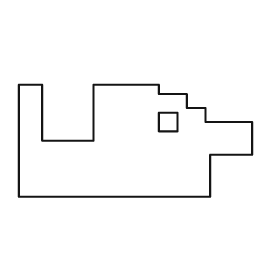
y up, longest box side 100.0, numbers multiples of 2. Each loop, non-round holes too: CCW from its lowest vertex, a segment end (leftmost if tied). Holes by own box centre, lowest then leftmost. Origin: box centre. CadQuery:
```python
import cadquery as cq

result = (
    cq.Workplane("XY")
    .moveTo(-50.0, -24.0)
    .lineTo(32.0, -24.0)
    .lineTo(32.0, -6.0)
    .lineTo(50.0, -6.0)
    .lineTo(50.0, 8.0)
    .lineTo(30.0, 8.0)
    .lineTo(30.0, 14.0)
    .lineTo(22.0, 14.0)
    .lineTo(22.0, 20.0)
    .lineTo(10.0, 20.0)
    .lineTo(10.0, 24.0)
    .lineTo(-18.0, 24.0)
    .lineTo(-18.0, 0.0)
    .lineTo(-40.0, 0.0)
    .lineTo(-40.0, 24.0)
    .lineTo(-50.0, 24.0)
    .close()
    .moveTo(10.0, 4.0)
    .lineTo(18.0, 4.0)
    .lineTo(18.0, 12.0)
    .lineTo(10.0, 12.0)
    .close()
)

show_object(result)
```